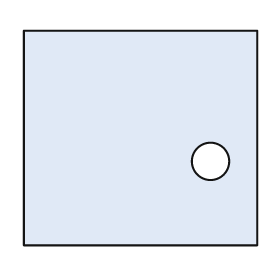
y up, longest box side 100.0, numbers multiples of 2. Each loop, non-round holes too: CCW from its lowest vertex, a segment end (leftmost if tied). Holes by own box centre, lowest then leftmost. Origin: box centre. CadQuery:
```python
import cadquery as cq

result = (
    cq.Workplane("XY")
    .moveTo(-50.0, -46.0)
    .lineTo(50.0, -46.0)
    .lineTo(50.0, 46.0)
    .lineTo(-50.0, 46.0)
    .close()
    .moveTo(30.0, -10.0)
    .circle(8.0)
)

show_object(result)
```